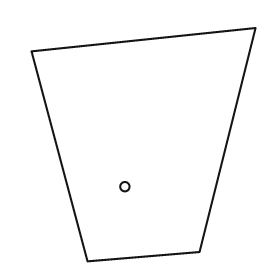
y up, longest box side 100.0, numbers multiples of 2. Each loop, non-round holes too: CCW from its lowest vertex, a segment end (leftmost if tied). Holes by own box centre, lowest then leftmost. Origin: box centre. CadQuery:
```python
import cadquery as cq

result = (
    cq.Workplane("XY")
    .moveTo(-24.0, -50.0)
    .lineTo(24.0, -46.0)
    .lineTo(48.0, 50.0)
    .lineTo(-48.0, 40.0)
    .close()
    .moveTo(-8.0, -18.0)
    .circle(2.0)
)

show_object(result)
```